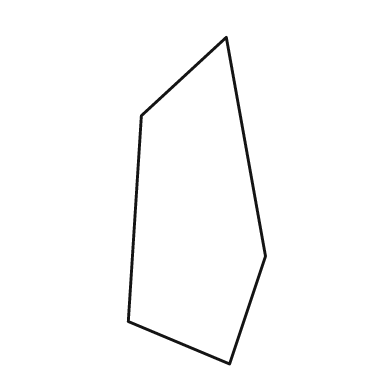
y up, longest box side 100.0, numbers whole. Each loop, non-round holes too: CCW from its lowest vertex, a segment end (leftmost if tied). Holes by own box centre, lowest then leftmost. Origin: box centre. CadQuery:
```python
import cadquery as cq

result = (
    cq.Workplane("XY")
    .moveTo(10.0, -50.0)
    .lineTo(21.0, -17.0)
    .lineTo(9.0, 50.0)
    .lineTo(-17.0, 26.0)
    .lineTo(-21.0, -37.0)
    .close()
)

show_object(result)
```